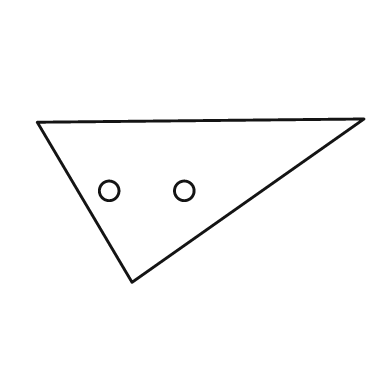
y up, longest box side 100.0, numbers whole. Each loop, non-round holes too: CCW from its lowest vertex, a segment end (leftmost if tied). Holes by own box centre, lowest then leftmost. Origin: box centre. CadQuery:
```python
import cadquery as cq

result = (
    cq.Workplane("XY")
    .moveTo(-21.0, -25.0)
    .lineTo(50.0, 25.0)
    .lineTo(-50.0, 24.0)
    .close()
    .moveTo(-28.0, 3.0)
    .circle(3.0)
    .moveTo(-5.0, 3.0)
    .circle(3.0)
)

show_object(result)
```